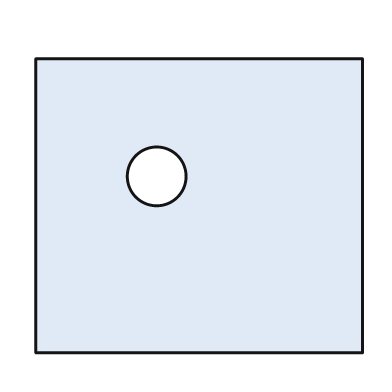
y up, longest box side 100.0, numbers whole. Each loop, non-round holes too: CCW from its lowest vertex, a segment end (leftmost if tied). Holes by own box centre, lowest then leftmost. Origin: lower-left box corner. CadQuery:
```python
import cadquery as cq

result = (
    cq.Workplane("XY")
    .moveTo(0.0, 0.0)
    .lineTo(100.0, 0.0)
    .lineTo(100.0, 90.0)
    .lineTo(0.0, 90.0)
    .close()
    .moveTo(37.0, 54.0)
    .circle(9.0)
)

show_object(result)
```